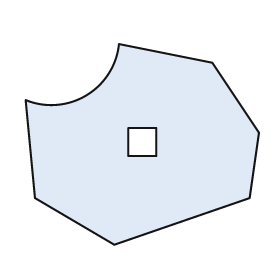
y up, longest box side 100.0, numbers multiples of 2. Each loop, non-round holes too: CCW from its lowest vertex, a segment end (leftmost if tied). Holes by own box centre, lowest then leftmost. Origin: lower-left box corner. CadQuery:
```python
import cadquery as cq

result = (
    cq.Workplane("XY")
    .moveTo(38.0, 0.0)
    .lineTo(96.0, 20.0)
    .lineTo(100.0, 48.0)
    .lineTo(80.0, 78.0)
    .lineTo(40.0, 86.0)
    .threePointArc((26.0, 64.0), (0.0, 62.0))
    .lineTo(4.0, 20.0)
    .close()
    .moveTo(44.0, 38.0)
    .lineTo(56.0, 38.0)
    .lineTo(56.0, 50.0)
    .lineTo(44.0, 50.0)
    .close()
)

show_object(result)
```